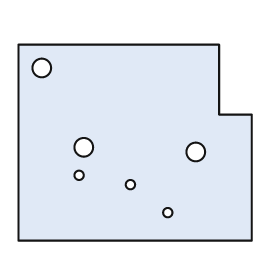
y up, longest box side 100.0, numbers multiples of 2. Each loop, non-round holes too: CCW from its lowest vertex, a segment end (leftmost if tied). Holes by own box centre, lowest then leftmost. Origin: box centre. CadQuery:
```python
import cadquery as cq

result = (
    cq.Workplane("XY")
    .moveTo(-50.0, -42.0)
    .lineTo(50.0, -42.0)
    .lineTo(50.0, 12.0)
    .lineTo(36.0, 12.0)
    .lineTo(36.0, 42.0)
    .lineTo(-50.0, 42.0)
    .close()
    .moveTo(14.0, -30.0)
    .circle(2.0)
    .moveTo(-2.0, -18.0)
    .circle(2.0)
    .moveTo(-24.0, -14.0)
    .circle(2.0)
    .moveTo(26.0, -4.0)
    .circle(4.0)
    .moveTo(-22.0, -2.0)
    .circle(4.0)
    .moveTo(-40.0, 32.0)
    .circle(4.0)
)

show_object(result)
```